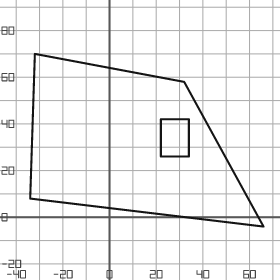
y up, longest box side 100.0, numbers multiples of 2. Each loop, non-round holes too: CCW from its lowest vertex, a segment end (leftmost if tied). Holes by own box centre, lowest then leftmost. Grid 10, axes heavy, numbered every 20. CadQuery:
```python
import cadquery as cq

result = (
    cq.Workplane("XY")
    .moveTo(66.0, -4.0)
    .lineTo(32.0, 58.0)
    .lineTo(-32.0, 70.0)
    .lineTo(-34.0, 8.0)
    .close()
    .moveTo(22.0, 26.0)
    .lineTo(34.0, 26.0)
    .lineTo(34.0, 42.0)
    .lineTo(22.0, 42.0)
    .close()
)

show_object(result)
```